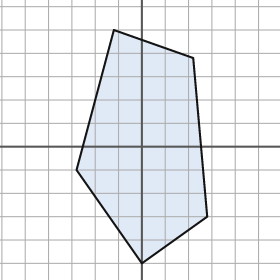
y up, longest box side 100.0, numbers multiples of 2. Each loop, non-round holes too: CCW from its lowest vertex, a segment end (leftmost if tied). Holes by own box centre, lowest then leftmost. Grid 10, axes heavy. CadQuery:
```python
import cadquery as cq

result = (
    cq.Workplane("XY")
    .moveTo(0.0, -50.0)
    .lineTo(28.0, -30.0)
    .lineTo(22.0, 38.0)
    .lineTo(-12.0, 50.0)
    .lineTo(-28.0, -10.0)
    .close()
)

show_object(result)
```